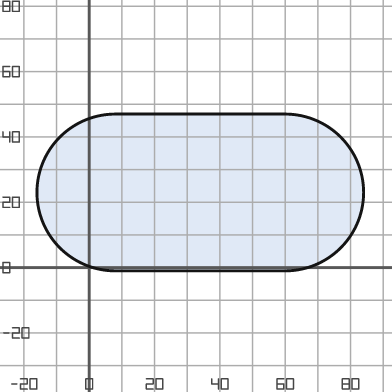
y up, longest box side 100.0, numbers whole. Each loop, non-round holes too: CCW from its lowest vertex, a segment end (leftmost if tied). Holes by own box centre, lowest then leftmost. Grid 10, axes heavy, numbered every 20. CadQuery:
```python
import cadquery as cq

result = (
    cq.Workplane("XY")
    .moveTo(8.0, -1.0)
    .lineTo(60.0, -1.0)
    .threePointArc((84.0, 23.0), (60.0, 47.0))
    .lineTo(8.0, 47.0)
    .threePointArc((-16.0, 23.0), (8.0, -1.0))
    .close()
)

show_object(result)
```